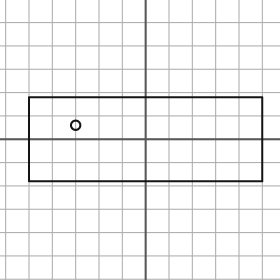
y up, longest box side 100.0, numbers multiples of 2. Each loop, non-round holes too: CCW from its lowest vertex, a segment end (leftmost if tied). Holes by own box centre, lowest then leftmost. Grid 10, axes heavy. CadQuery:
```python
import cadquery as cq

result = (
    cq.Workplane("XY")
    .moveTo(-50.0, -18.0)
    .lineTo(50.0, -18.0)
    .lineTo(50.0, 18.0)
    .lineTo(-50.0, 18.0)
    .close()
    .moveTo(-30.0, 6.0)
    .circle(2.0)
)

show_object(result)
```